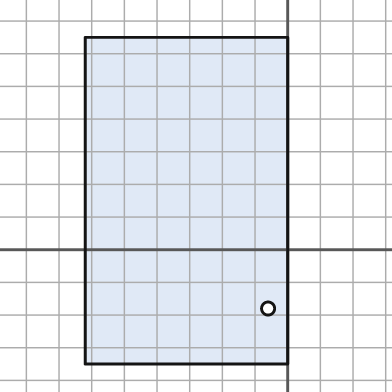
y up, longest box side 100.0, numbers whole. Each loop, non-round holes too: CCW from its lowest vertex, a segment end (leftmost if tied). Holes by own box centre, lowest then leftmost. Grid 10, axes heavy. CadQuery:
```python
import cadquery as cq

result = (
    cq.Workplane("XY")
    .moveTo(-62.0, -35.0)
    .lineTo(0.0, -35.0)
    .lineTo(0.0, 65.0)
    .lineTo(-62.0, 65.0)
    .close()
    .moveTo(-6.0, -18.0)
    .circle(2.0)
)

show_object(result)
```